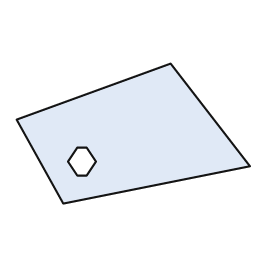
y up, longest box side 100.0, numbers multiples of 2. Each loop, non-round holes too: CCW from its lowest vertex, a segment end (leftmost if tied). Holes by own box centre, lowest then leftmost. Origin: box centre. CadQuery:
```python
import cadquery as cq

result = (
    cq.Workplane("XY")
    .moveTo(-30.0, -30.0)
    .lineTo(50.0, -14.0)
    .lineTo(16.0, 30.0)
    .lineTo(-50.0, 6.0)
    .close()
    .moveTo(-24.0, -18.0)
    .lineTo(-20.0, -18.0)
    .lineTo(-16.0, -12.0)
    .lineTo(-20.0, -6.0)
    .lineTo(-24.0, -6.0)
    .lineTo(-28.0, -12.0)
    .close()
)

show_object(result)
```